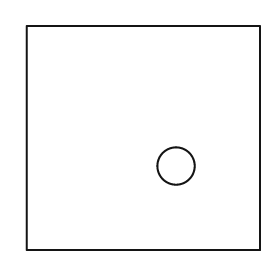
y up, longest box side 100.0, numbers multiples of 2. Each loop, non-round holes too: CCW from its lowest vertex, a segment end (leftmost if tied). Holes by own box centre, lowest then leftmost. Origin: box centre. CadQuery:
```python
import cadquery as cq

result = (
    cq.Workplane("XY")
    .moveTo(-50.0, -48.0)
    .lineTo(50.0, -48.0)
    .lineTo(50.0, 48.0)
    .lineTo(-50.0, 48.0)
    .close()
    .moveTo(14.0, -12.0)
    .circle(8.0)
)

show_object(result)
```